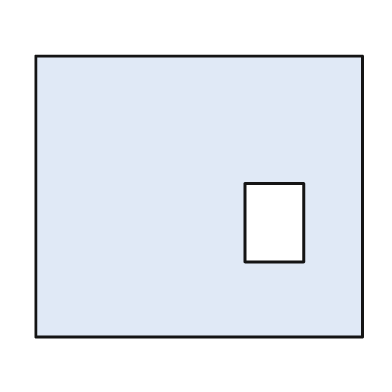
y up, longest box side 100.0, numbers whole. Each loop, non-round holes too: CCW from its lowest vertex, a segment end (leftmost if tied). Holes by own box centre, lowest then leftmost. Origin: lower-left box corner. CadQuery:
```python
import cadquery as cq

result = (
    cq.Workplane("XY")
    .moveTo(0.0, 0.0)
    .lineTo(100.0, 0.0)
    .lineTo(100.0, 86.0)
    .lineTo(0.0, 86.0)
    .close()
    .moveTo(64.0, 23.0)
    .lineTo(82.0, 23.0)
    .lineTo(82.0, 47.0)
    .lineTo(64.0, 47.0)
    .close()
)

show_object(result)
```